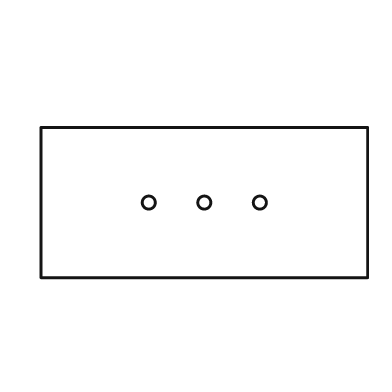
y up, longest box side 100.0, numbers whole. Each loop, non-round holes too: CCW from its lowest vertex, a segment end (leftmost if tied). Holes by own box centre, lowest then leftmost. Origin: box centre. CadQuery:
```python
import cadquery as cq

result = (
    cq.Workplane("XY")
    .moveTo(-50.0, -23.0)
    .lineTo(50.0, -23.0)
    .lineTo(50.0, 23.0)
    .lineTo(-50.0, 23.0)
    .close()
    .moveTo(-17.0, 0.0)
    .circle(2.0)
    .moveTo(0.0, 0.0)
    .circle(2.0)
    .moveTo(17.0, 0.0)
    .circle(2.0)
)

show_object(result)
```